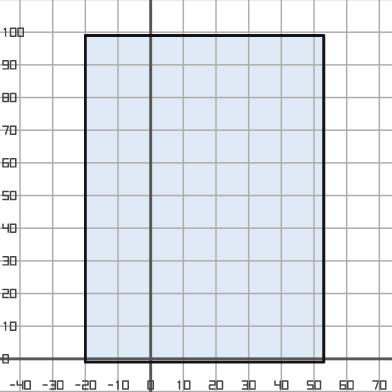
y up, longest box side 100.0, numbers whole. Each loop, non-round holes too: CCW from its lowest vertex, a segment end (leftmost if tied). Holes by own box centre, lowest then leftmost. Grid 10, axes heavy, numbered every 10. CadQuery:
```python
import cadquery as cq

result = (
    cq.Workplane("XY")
    .moveTo(-20.0, -1.0)
    .lineTo(53.0, -1.0)
    .lineTo(53.0, 99.0)
    .lineTo(-20.0, 99.0)
    .close()
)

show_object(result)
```